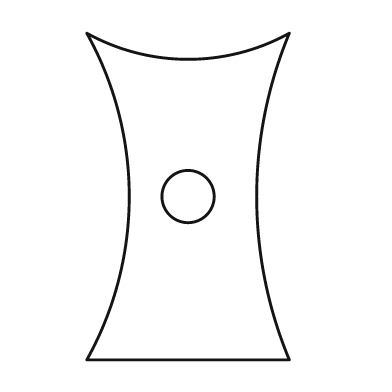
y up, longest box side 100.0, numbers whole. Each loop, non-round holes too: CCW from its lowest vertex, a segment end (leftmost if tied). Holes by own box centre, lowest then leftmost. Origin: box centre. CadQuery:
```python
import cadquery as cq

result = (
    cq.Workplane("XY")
    .moveTo(-31.0, -50.0)
    .lineTo(31.0, -50.0)
    .threePointArc((21.0, 0.0), (31.0, 50.0))
    .threePointArc((0.0, 42.0), (-31.0, 50.0))
    .threePointArc((-18.0, 0.0), (-31.0, -50.0))
    .close()
    .moveTo(0.0, 0.0)
    .circle(8.0)
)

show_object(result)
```